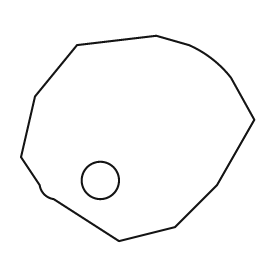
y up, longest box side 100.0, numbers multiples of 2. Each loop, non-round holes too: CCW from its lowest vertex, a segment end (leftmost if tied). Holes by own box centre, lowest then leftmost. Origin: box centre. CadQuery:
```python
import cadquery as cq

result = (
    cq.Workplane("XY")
    .moveTo(-8.0, -44.0)
    .lineTo(16.0, -38.0)
    .lineTo(34.0, -20.0)
    .lineTo(50.0, 8.0)
    .lineTo(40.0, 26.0)
    .threePointArc((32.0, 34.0), (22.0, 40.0))
    .lineTo(8.0, 44.0)
    .lineTo(-26.0, 40.0)
    .lineTo(-44.0, 18.0)
    .lineTo(-50.0, -8.0)
    .lineTo(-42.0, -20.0)
    .threePointArc((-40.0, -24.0), (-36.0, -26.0))
    .close()
    .moveTo(-16.0, -18.0)
    .circle(8.0)
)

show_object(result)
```